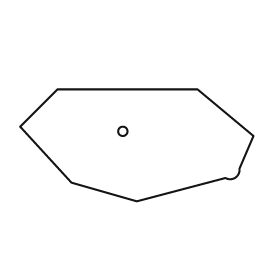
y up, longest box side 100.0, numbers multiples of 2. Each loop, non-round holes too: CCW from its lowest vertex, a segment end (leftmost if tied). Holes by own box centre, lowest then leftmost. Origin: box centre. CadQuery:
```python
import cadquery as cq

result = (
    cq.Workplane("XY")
    .moveTo(0.0, -24.0)
    .lineTo(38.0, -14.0)
    .threePointArc((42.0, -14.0), (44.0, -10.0))
    .lineTo(50.0, 4.0)
    .lineTo(26.0, 24.0)
    .lineTo(-34.0, 24.0)
    .lineTo(-50.0, 8.0)
    .lineTo(-28.0, -16.0)
    .close()
    .moveTo(-6.0, 6.0)
    .circle(2.0)
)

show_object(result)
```